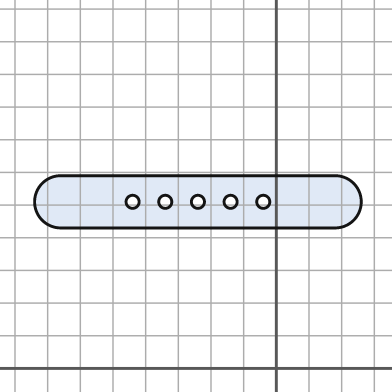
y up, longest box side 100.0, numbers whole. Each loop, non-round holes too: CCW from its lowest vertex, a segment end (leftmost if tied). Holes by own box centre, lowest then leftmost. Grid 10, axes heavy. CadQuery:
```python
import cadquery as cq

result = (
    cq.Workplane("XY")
    .moveTo(-66.0, 43.0)
    .lineTo(18.0, 43.0)
    .threePointArc((26.0, 51.0), (18.0, 59.0))
    .lineTo(-66.0, 59.0)
    .threePointArc((-74.0, 51.0), (-66.0, 43.0))
    .close()
    .moveTo(-44.0, 51.0)
    .circle(2.0)
    .moveTo(-34.0, 51.0)
    .circle(2.0)
    .moveTo(-24.0, 51.0)
    .circle(2.0)
    .moveTo(-14.0, 51.0)
    .circle(2.0)
    .moveTo(-4.0, 51.0)
    .circle(2.0)
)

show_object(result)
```